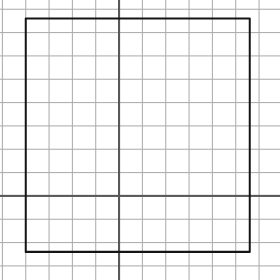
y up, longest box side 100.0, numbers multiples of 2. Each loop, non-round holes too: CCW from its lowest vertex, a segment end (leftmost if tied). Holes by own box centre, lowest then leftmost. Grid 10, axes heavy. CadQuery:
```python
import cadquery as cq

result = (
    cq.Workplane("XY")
    .moveTo(-40.0, -24.0)
    .lineTo(56.0, -24.0)
    .lineTo(56.0, 76.0)
    .lineTo(-40.0, 76.0)
    .close()
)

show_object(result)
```